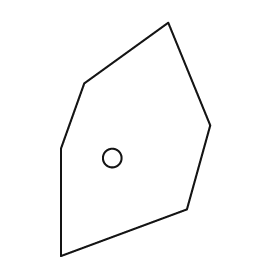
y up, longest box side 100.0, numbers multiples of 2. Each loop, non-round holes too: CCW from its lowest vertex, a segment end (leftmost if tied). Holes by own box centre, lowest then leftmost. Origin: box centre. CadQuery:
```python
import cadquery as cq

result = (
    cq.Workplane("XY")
    .moveTo(-32.0, -50.0)
    .lineTo(22.0, -30.0)
    .lineTo(32.0, 6.0)
    .lineTo(14.0, 50.0)
    .lineTo(-22.0, 24.0)
    .lineTo(-32.0, -4.0)
    .close()
    .moveTo(-10.0, -8.0)
    .circle(4.0)
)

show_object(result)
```